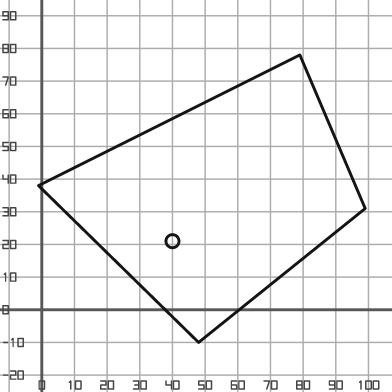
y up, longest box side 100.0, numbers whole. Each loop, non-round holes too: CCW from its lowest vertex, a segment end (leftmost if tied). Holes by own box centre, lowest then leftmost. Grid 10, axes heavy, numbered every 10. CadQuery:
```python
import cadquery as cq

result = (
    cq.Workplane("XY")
    .moveTo(48.0, -10.0)
    .lineTo(99.0, 31.0)
    .lineTo(79.0, 78.0)
    .lineTo(-1.0, 38.0)
    .close()
    .moveTo(40.0, 21.0)
    .circle(2.0)
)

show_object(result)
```